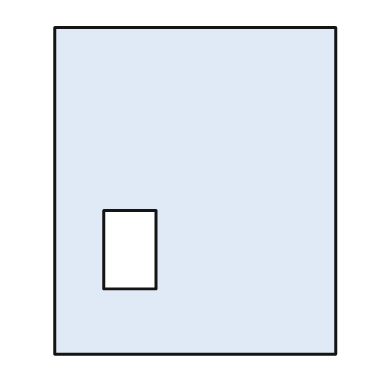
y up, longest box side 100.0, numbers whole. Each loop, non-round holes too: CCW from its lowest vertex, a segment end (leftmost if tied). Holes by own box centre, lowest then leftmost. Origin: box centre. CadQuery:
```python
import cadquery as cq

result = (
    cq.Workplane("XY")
    .moveTo(-43.0, -50.0)
    .lineTo(43.0, -50.0)
    .lineTo(43.0, 50.0)
    .lineTo(-43.0, 50.0)
    .close()
    .moveTo(-28.0, -30.0)
    .lineTo(-12.0, -30.0)
    .lineTo(-12.0, -6.0)
    .lineTo(-28.0, -6.0)
    .close()
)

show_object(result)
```